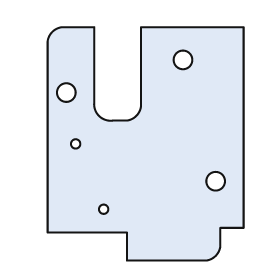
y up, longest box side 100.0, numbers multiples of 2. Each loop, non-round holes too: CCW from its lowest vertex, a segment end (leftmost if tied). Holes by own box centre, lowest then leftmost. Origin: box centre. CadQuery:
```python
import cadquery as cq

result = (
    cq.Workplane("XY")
    .moveTo(-8.0, -50.0)
    .lineTo(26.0, -50.0)
    .threePointArc((30.0, -48.0), (32.0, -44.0))
    .lineTo(32.0, -36.0)
    .lineTo(42.0, -36.0)
    .lineTo(42.0, 50.0)
    .lineTo(-2.0, 50.0)
    .lineTo(-2.0, 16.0)
    .threePointArc((-4.0, 12.0), (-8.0, 10.0))
    .lineTo(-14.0, 10.0)
    .threePointArc((-20.0, 12.0), (-22.0, 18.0))
    .lineTo(-22.0, 50.0)
    .lineTo(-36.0, 50.0)
    .threePointArc((-40.0, 48.0), (-42.0, 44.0))
    .lineTo(-42.0, -38.0)
    .lineTo(-8.0, -38.0)
    .close()
    .moveTo(-18.0, -28.0)
    .circle(2.0)
    .moveTo(30.0, -16.0)
    .circle(4.0)
    .moveTo(-30.0, 0.0)
    .circle(2.0)
    .moveTo(-34.0, 22.0)
    .circle(4.0)
    .moveTo(16.0, 36.0)
    .circle(4.0)
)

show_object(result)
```